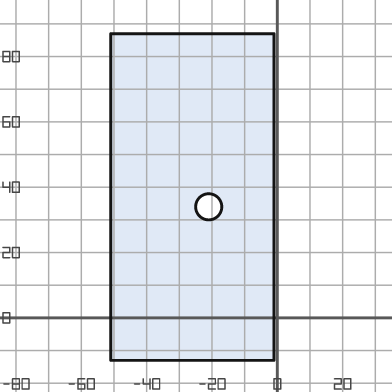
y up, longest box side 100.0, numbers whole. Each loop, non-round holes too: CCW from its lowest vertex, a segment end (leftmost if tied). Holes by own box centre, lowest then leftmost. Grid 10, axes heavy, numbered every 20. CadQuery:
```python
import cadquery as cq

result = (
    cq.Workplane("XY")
    .moveTo(-51.0, -13.0)
    .lineTo(-1.0, -13.0)
    .lineTo(-1.0, 87.0)
    .lineTo(-51.0, 87.0)
    .close()
    .moveTo(-21.0, 34.0)
    .circle(4.0)
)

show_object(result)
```